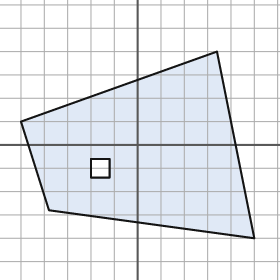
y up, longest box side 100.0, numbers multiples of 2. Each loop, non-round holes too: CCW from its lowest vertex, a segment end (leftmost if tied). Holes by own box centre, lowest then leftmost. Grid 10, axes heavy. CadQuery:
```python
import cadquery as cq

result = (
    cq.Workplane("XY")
    .moveTo(50.0, -40.0)
    .lineTo(34.0, 40.0)
    .lineTo(-50.0, 10.0)
    .lineTo(-38.0, -28.0)
    .close()
    .moveTo(-20.0, -14.0)
    .lineTo(-12.0, -14.0)
    .lineTo(-12.0, -6.0)
    .lineTo(-20.0, -6.0)
    .close()
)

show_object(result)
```